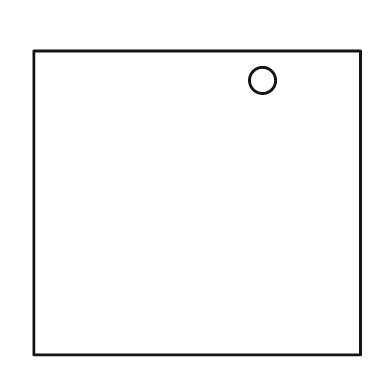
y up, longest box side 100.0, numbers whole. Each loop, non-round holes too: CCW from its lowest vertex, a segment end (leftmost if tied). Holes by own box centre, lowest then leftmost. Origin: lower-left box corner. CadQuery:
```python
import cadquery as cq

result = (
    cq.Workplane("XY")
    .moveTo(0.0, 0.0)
    .lineTo(100.0, 0.0)
    .lineTo(100.0, 93.0)
    .lineTo(0.0, 93.0)
    .close()
    .moveTo(70.0, 84.0)
    .circle(4.0)
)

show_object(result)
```